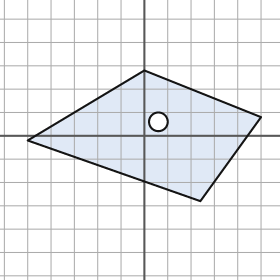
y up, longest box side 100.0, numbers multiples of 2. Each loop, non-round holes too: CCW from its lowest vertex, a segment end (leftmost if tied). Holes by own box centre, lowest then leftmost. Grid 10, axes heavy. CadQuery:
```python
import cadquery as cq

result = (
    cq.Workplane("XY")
    .moveTo(24.0, -28.0)
    .lineTo(50.0, 8.0)
    .lineTo(0.0, 28.0)
    .lineTo(-50.0, -2.0)
    .close()
    .moveTo(6.0, 6.0)
    .circle(4.0)
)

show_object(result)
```